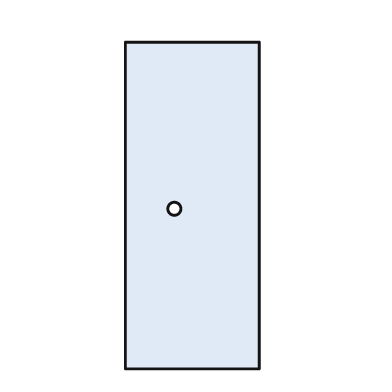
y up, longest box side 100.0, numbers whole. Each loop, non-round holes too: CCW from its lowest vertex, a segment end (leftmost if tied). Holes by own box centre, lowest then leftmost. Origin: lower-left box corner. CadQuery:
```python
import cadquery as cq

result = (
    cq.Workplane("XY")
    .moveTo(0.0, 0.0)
    .lineTo(41.0, 0.0)
    .lineTo(41.0, 100.0)
    .lineTo(0.0, 100.0)
    .close()
    .moveTo(15.0, 49.0)
    .circle(2.0)
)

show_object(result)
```